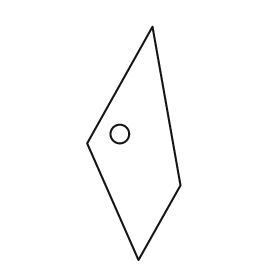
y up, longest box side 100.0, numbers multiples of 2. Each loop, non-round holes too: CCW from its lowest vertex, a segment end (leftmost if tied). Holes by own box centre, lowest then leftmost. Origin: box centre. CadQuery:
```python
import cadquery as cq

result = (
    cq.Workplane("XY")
    .moveTo(2.0, -50.0)
    .lineTo(20.0, -18.0)
    .lineTo(8.0, 50.0)
    .lineTo(-20.0, 0.0)
    .close()
    .moveTo(-6.0, 4.0)
    .circle(4.0)
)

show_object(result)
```